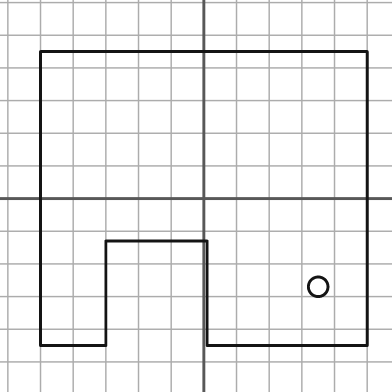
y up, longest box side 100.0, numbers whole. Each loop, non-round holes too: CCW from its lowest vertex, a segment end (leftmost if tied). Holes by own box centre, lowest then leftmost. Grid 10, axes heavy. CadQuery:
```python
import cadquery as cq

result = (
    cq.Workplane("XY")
    .moveTo(-50.0, -45.0)
    .lineTo(-30.0, -45.0)
    .lineTo(-30.0, -13.0)
    .lineTo(1.0, -13.0)
    .lineTo(1.0, -45.0)
    .lineTo(50.0, -45.0)
    .lineTo(50.0, 45.0)
    .lineTo(-50.0, 45.0)
    .close()
    .moveTo(35.0, -27.0)
    .circle(3.0)
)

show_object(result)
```